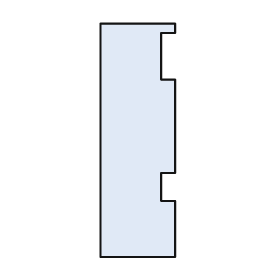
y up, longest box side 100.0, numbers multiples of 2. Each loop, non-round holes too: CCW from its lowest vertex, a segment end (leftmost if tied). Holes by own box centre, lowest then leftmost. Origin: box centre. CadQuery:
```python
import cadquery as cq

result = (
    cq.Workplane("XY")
    .moveTo(-16.0, -50.0)
    .lineTo(16.0, -50.0)
    .lineTo(16.0, -26.0)
    .lineTo(10.0, -26.0)
    .lineTo(10.0, -14.0)
    .lineTo(16.0, -14.0)
    .lineTo(16.0, 26.0)
    .lineTo(10.0, 26.0)
    .lineTo(10.0, 46.0)
    .lineTo(16.0, 46.0)
    .lineTo(16.0, 50.0)
    .lineTo(-16.0, 50.0)
    .close()
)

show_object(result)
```